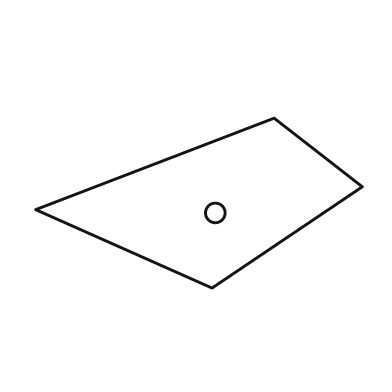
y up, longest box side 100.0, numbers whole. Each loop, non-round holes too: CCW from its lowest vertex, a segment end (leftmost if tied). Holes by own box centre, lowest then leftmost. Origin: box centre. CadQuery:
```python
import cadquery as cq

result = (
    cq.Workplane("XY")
    .moveTo(4.0, -26.0)
    .lineTo(50.0, 5.0)
    .lineTo(23.0, 26.0)
    .lineTo(-50.0, -2.0)
    .close()
    .moveTo(5.0, -3.0)
    .circle(3.0)
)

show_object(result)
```